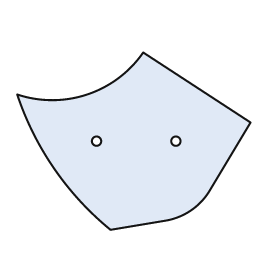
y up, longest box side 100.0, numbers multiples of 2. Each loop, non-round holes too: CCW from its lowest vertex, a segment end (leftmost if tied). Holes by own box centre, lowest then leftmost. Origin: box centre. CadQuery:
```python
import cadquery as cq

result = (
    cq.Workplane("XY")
    .moveTo(-10.0, -38.0)
    .lineTo(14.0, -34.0)
    .threePointArc((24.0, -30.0), (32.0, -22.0))
    .lineTo(50.0, 8.0)
    .lineTo(4.0, 38.0)
    .threePointArc((-20.0, 20.0), (-50.0, 20.0))
    .threePointArc((-34.0, -12.0), (-10.0, -38.0))
    .close()
    .moveTo(-16.0, 0.0)
    .circle(2.0)
    .moveTo(18.0, 0.0)
    .circle(2.0)
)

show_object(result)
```